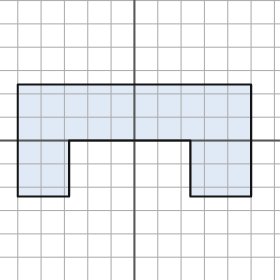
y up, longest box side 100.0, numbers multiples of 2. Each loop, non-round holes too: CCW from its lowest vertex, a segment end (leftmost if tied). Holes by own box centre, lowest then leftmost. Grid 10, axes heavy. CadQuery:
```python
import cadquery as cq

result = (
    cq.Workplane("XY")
    .moveTo(-50.0, -24.0)
    .lineTo(-28.0, -24.0)
    .lineTo(-28.0, 0.0)
    .lineTo(24.0, 0.0)
    .lineTo(24.0, -24.0)
    .lineTo(50.0, -24.0)
    .lineTo(50.0, 24.0)
    .lineTo(-50.0, 24.0)
    .close()
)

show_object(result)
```